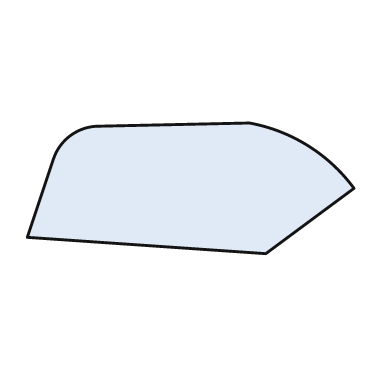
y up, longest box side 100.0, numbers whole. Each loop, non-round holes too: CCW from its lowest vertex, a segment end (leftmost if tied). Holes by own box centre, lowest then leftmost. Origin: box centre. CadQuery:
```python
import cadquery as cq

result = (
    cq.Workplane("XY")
    .moveTo(23.0, -20.0)
    .lineTo(50.0, 0.0)
    .threePointArc((36.0, 13.0), (18.0, 20.0))
    .lineTo(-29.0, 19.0)
    .threePointArc((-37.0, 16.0), (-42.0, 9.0))
    .lineTo(-50.0, -15.0)
    .close()
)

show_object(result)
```